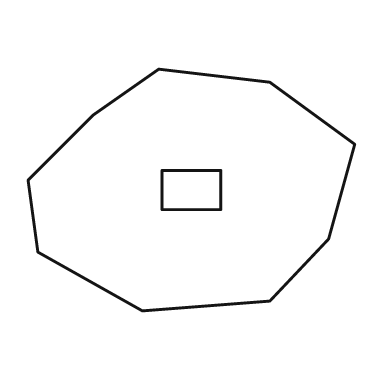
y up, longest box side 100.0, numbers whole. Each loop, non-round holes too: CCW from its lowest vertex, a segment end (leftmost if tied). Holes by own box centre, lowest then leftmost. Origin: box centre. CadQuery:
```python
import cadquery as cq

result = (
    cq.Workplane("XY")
    .moveTo(-15.0, -37.0)
    .lineTo(24.0, -34.0)
    .lineTo(42.0, -15.0)
    .lineTo(50.0, 14.0)
    .lineTo(24.0, 33.0)
    .lineTo(-10.0, 37.0)
    .lineTo(-30.0, 23.0)
    .lineTo(-50.0, 3.0)
    .lineTo(-47.0, -19.0)
    .close()
    .moveTo(-9.0, -6.0)
    .lineTo(9.0, -6.0)
    .lineTo(9.0, 6.0)
    .lineTo(-9.0, 6.0)
    .close()
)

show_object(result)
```